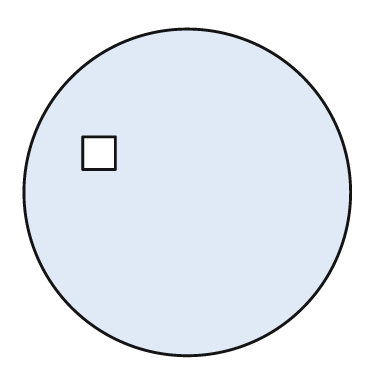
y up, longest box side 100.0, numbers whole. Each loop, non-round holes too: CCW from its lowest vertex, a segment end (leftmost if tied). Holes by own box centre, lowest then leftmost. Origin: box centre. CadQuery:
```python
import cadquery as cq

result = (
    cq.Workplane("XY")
    .moveTo(0.0, 0.0)
    .circle(50.0)
    .moveTo(-32.0, 7.0)
    .lineTo(-22.0, 7.0)
    .lineTo(-22.0, 17.0)
    .lineTo(-32.0, 17.0)
    .close()
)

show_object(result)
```